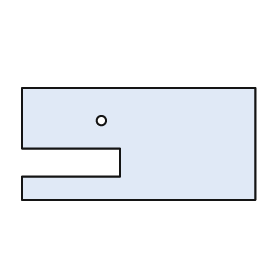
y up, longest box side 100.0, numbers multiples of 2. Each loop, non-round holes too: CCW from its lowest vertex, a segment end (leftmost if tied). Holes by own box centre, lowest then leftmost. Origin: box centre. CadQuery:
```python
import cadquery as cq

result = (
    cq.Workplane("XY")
    .moveTo(-50.0, -24.0)
    .lineTo(50.0, -24.0)
    .lineTo(50.0, 24.0)
    .lineTo(-50.0, 24.0)
    .lineTo(-50.0, -2.0)
    .lineTo(-8.0, -2.0)
    .lineTo(-8.0, -14.0)
    .lineTo(-50.0, -14.0)
    .close()
    .moveTo(-16.0, 10.0)
    .circle(2.0)
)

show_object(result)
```